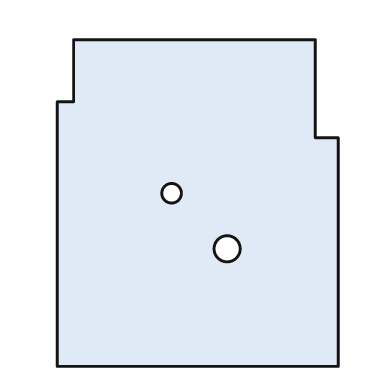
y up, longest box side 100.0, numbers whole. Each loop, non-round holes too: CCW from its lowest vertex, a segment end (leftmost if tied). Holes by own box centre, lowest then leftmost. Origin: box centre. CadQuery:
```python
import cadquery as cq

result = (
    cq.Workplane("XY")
    .moveTo(-43.0, -50.0)
    .lineTo(43.0, -50.0)
    .lineTo(43.0, 20.0)
    .lineTo(36.0, 20.0)
    .lineTo(36.0, 50.0)
    .lineTo(-38.0, 50.0)
    .lineTo(-38.0, 31.0)
    .lineTo(-43.0, 31.0)
    .close()
    .moveTo(9.0, -14.0)
    .circle(4.0)
    .moveTo(-8.0, 3.0)
    .circle(3.0)
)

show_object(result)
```